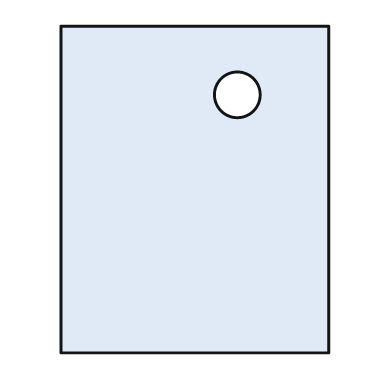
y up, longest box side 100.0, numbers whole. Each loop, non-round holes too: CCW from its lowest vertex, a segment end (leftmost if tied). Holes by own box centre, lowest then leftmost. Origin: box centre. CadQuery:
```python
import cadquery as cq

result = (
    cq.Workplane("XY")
    .moveTo(-41.0, -50.0)
    .lineTo(41.0, -50.0)
    .lineTo(41.0, 50.0)
    .lineTo(-41.0, 50.0)
    .close()
    .moveTo(13.0, 29.0)
    .circle(7.0)
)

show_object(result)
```